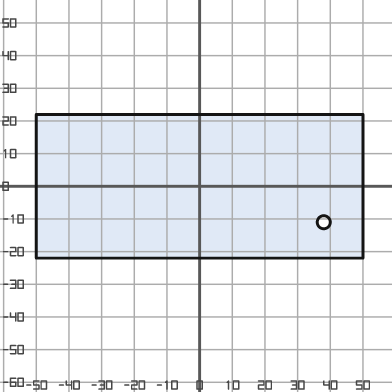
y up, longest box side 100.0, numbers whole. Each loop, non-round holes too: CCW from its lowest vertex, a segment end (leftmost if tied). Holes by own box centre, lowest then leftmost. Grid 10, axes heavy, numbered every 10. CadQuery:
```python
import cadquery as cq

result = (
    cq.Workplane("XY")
    .moveTo(-50.0, -22.0)
    .lineTo(50.0, -22.0)
    .lineTo(50.0, 22.0)
    .lineTo(-50.0, 22.0)
    .close()
    .moveTo(38.0, -11.0)
    .circle(2.0)
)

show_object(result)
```